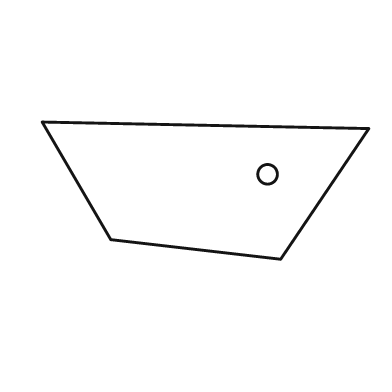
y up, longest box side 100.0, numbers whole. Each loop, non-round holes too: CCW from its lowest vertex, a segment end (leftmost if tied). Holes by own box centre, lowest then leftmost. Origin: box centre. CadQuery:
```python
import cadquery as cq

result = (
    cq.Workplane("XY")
    .moveTo(23.0, -21.0)
    .lineTo(50.0, 19.0)
    .lineTo(-50.0, 21.0)
    .lineTo(-29.0, -15.0)
    .close()
    .moveTo(19.0, 5.0)
    .circle(3.0)
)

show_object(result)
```